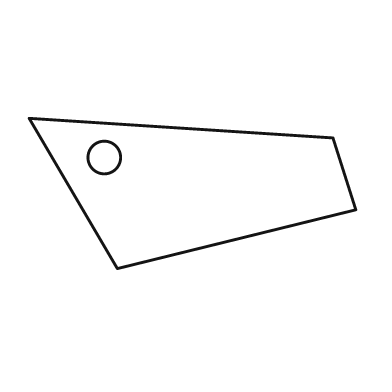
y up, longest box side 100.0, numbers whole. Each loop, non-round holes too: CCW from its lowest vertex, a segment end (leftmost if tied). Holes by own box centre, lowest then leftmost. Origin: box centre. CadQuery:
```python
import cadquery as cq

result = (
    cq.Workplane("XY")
    .moveTo(-23.0, -23.0)
    .lineTo(50.0, -5.0)
    .lineTo(43.0, 17.0)
    .lineTo(-50.0, 23.0)
    .close()
    .moveTo(-27.0, 11.0)
    .circle(5.0)
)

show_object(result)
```